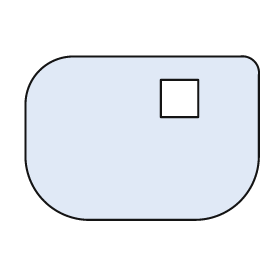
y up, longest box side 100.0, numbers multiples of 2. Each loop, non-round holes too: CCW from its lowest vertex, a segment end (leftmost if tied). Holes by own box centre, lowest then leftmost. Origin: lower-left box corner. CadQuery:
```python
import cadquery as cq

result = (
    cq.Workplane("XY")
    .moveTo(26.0, 0.0)
    .lineTo(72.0, 0.0)
    .threePointArc((92.0, 8.0), (100.0, 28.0))
    .lineTo(100.0, 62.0)
    .threePointArc((98.0, 68.0), (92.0, 70.0))
    .lineTo(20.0, 70.0)
    .threePointArc((6.0, 64.0), (0.0, 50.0))
    .lineTo(0.0, 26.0)
    .threePointArc((8.0, 8.0), (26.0, 0.0))
    .close()
    .moveTo(58.0, 44.0)
    .lineTo(74.0, 44.0)
    .lineTo(74.0, 60.0)
    .lineTo(58.0, 60.0)
    .close()
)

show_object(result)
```